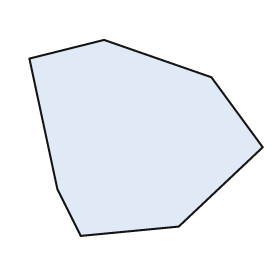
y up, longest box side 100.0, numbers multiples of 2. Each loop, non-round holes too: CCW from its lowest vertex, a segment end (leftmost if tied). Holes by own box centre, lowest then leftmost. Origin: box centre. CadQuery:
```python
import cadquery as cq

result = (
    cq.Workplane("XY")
    .moveTo(-28.0, -42.0)
    .lineTo(14.0, -38.0)
    .lineTo(50.0, -4.0)
    .lineTo(28.0, 26.0)
    .lineTo(-18.0, 42.0)
    .lineTo(-50.0, 34.0)
    .lineTo(-38.0, -22.0)
    .close()
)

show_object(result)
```